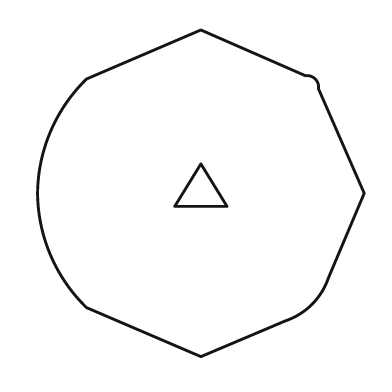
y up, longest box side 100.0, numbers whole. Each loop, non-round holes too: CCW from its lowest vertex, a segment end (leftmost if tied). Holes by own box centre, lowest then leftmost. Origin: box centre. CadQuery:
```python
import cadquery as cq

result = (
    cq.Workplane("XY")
    .moveTo(0.0, -50.0)
    .lineTo(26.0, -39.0)
    .threePointArc((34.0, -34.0), (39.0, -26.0))
    .lineTo(50.0, 0.0)
    .lineTo(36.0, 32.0)
    .threePointArc((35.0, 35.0), (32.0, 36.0))
    .lineTo(0.0, 50.0)
    .lineTo(-35.0, 35.0)
    .threePointArc((-46.0, 19.0), (-50.0, 0.0))
    .threePointArc((-46.0, -19.0), (-35.0, -35.0))
    .close()
    .moveTo(-8.0, -4.0)
    .lineTo(8.0, -4.0)
    .lineTo(0.0, 9.0)
    .close()
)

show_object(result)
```